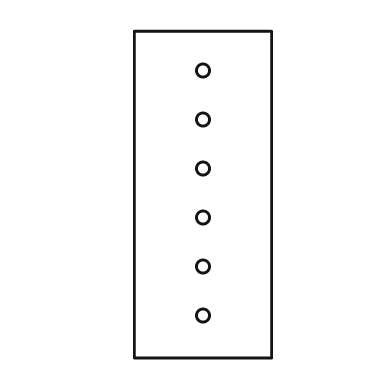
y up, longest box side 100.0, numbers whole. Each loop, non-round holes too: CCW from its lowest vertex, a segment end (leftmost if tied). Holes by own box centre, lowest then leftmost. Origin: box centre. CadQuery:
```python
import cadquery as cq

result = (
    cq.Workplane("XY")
    .moveTo(-21.0, -50.0)
    .lineTo(21.0, -50.0)
    .lineTo(21.0, 50.0)
    .lineTo(-21.0, 50.0)
    .close()
    .moveTo(0.0, -37.0)
    .circle(2.0)
    .moveTo(0.0, -22.0)
    .circle(2.0)
    .moveTo(0.0, -7.0)
    .circle(2.0)
    .moveTo(0.0, 8.0)
    .circle(2.0)
    .moveTo(0.0, 23.0)
    .circle(2.0)
    .moveTo(0.0, 38.0)
    .circle(2.0)
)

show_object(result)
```